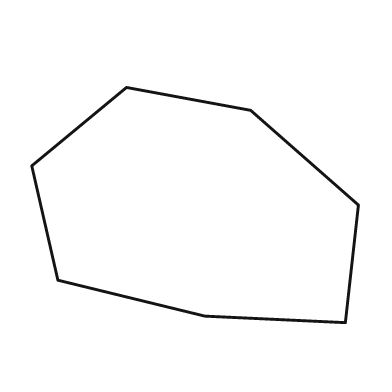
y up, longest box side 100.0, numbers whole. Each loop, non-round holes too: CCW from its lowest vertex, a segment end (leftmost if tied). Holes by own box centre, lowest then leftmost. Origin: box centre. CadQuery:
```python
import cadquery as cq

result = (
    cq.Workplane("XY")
    .moveTo(46.0, -36.0)
    .lineTo(50.0, 0.0)
    .lineTo(17.0, 29.0)
    .lineTo(-21.0, 36.0)
    .lineTo(-50.0, 12.0)
    .lineTo(-42.0, -23.0)
    .lineTo(3.0, -34.0)
    .close()
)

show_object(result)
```